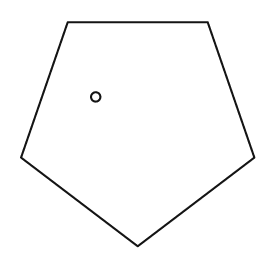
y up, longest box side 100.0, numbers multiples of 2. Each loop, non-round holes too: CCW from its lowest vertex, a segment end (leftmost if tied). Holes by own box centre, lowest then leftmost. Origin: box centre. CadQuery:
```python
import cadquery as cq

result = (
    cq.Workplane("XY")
    .moveTo(0.0, -48.0)
    .lineTo(50.0, -10.0)
    .lineTo(30.0, 48.0)
    .lineTo(-30.0, 48.0)
    .lineTo(-50.0, -10.0)
    .close()
    .moveTo(-18.0, 16.0)
    .circle(2.0)
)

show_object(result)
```